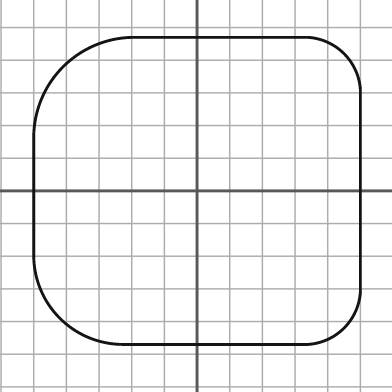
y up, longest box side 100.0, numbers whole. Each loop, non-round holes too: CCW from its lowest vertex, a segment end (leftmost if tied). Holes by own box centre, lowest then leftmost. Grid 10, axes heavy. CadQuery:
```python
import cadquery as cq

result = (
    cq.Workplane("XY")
    .moveTo(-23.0, -47.0)
    .lineTo(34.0, -47.0)
    .threePointArc((45.0, -42.0), (50.0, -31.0))
    .lineTo(50.0, 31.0)
    .threePointArc((45.0, 42.0), (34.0, 47.0))
    .lineTo(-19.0, 47.0)
    .threePointArc((-41.0, 38.0), (-50.0, 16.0))
    .lineTo(-50.0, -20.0)
    .threePointArc((-42.0, -39.0), (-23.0, -47.0))
    .close()
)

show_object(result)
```